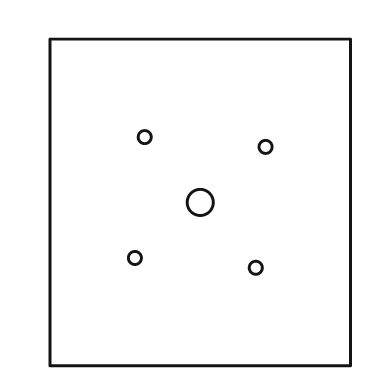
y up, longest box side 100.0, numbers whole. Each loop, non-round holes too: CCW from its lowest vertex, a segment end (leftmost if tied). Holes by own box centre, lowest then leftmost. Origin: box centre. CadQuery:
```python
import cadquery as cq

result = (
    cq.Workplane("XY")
    .moveTo(-46.0, -50.0)
    .lineTo(46.0, -50.0)
    .lineTo(46.0, 50.0)
    .lineTo(-46.0, 50.0)
    .close()
    .moveTo(17.0, -20.0)
    .circle(2.0)
    .moveTo(-20.0, -17.0)
    .circle(2.0)
    .moveTo(0.0, 0.0)
    .circle(4.0)
    .moveTo(20.0, 17.0)
    .circle(2.0)
    .moveTo(-17.0, 20.0)
    .circle(2.0)
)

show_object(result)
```